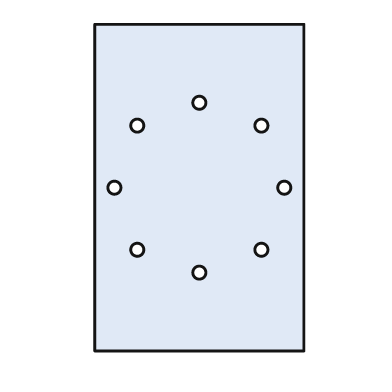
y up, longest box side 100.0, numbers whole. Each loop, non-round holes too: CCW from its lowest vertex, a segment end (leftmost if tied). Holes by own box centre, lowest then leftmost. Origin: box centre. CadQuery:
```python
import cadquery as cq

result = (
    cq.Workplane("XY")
    .moveTo(-32.0, -50.0)
    .lineTo(32.0, -50.0)
    .lineTo(32.0, 50.0)
    .lineTo(-32.0, 50.0)
    .close()
    .moveTo(0.0, -26.0)
    .circle(2.0)
    .moveTo(-19.0, -19.0)
    .circle(2.0)
    .moveTo(19.0, -19.0)
    .circle(2.0)
    .moveTo(-26.0, 0.0)
    .circle(2.0)
    .moveTo(26.0, 0.0)
    .circle(2.0)
    .moveTo(-19.0, 19.0)
    .circle(2.0)
    .moveTo(19.0, 19.0)
    .circle(2.0)
    .moveTo(0.0, 26.0)
    .circle(2.0)
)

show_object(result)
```